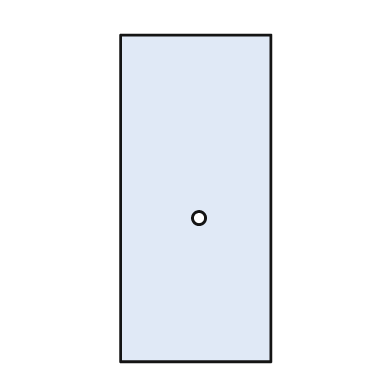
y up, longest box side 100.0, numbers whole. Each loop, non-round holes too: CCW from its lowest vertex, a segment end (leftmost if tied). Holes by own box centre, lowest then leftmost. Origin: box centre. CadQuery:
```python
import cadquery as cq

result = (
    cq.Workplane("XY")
    .moveTo(-23.0, -50.0)
    .lineTo(23.0, -50.0)
    .lineTo(23.0, 50.0)
    .lineTo(-23.0, 50.0)
    .close()
    .moveTo(1.0, -6.0)
    .circle(2.0)
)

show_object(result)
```